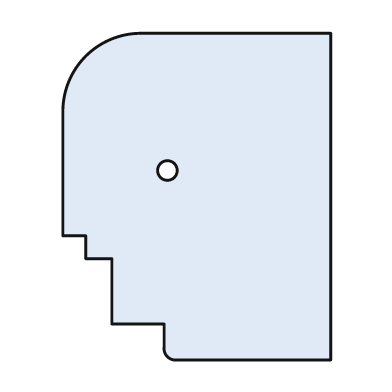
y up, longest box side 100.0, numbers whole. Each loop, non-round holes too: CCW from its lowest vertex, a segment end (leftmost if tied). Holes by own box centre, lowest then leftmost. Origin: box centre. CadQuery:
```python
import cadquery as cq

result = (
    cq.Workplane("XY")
    .moveTo(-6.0, -50.0)
    .lineTo(41.0, -50.0)
    .lineTo(41.0, 50.0)
    .lineTo(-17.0, 50.0)
    .threePointArc((-34.0, 43.0), (-41.0, 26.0))
    .lineTo(-41.0, -12.0)
    .lineTo(-34.0, -12.0)
    .lineTo(-34.0, -19.0)
    .lineTo(-26.0, -19.0)
    .lineTo(-26.0, -39.0)
    .lineTo(-10.0, -39.0)
    .lineTo(-10.0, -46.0)
    .threePointArc((-9.0, -49.0), (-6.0, -50.0))
    .close()
    .moveTo(-9.0, 8.0)
    .circle(3.0)
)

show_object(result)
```